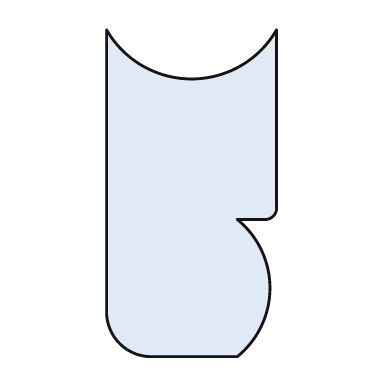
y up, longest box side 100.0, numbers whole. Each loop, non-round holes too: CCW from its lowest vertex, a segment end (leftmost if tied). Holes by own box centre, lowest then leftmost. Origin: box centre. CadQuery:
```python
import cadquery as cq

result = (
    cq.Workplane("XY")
    .moveTo(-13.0, -50.0)
    .lineTo(14.0, -50.0)
    .threePointArc((24.0, -29.0), (14.0, -8.0))
    .lineTo(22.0, -8.0)
    .threePointArc((25.0, -7.0), (26.0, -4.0))
    .lineTo(26.0, 50.0)
    .threePointArc((0.0, 35.0), (-26.0, 50.0))
    .lineTo(-26.0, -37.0)
    .threePointArc((-22.0, -46.0), (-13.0, -50.0))
    .close()
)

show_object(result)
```